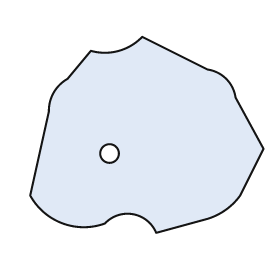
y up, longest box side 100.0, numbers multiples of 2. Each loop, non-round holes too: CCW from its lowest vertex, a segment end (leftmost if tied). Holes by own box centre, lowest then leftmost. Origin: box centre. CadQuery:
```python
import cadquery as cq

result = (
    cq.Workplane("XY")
    .moveTo(4.0, -42.0)
    .lineTo(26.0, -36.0)
    .threePointArc((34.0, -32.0), (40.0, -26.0))
    .lineTo(50.0, -6.0)
    .lineTo(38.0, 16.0)
    .threePointArc((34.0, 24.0), (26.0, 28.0))
    .lineTo(-2.0, 42.0)
    .threePointArc((-12.0, 36.0), (-24.0, 36.0))
    .lineTo(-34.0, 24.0)
    .threePointArc((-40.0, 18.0), (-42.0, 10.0))
    .lineTo(-50.0, -26.0)
    .threePointArc((-36.0, -38.0), (-18.0, -38.0))
    .threePointArc((-6.0, -34.0), (4.0, -42.0))
    .close()
    .moveTo(-16.0, -8.0)
    .circle(4.0)
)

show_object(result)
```